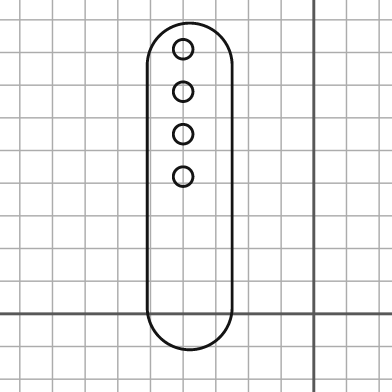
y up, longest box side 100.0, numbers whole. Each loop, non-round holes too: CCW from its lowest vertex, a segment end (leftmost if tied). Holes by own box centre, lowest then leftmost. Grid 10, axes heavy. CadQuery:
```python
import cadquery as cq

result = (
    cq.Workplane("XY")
    .moveTo(-51.0, 2.0)
    .threePointArc((-38.0, -11.0), (-25.0, 2.0))
    .lineTo(-25.0, 76.0)
    .threePointArc((-38.0, 89.0), (-51.0, 76.0))
    .close()
    .moveTo(-40.0, 42.0)
    .circle(3.0)
    .moveTo(-40.0, 55.0)
    .circle(3.0)
    .moveTo(-40.0, 68.0)
    .circle(3.0)
    .moveTo(-40.0, 81.0)
    .circle(3.0)
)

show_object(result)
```